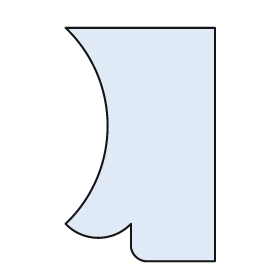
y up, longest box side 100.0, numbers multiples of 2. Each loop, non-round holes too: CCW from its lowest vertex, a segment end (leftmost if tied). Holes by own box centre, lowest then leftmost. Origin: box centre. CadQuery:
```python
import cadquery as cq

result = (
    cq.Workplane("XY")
    .moveTo(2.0, -50.0)
    .lineTo(32.0, -50.0)
    .lineTo(32.0, 50.0)
    .lineTo(-32.0, 50.0)
    .threePointArc((-14.0, 8.0), (-32.0, -34.0))
    .threePointArc((-18.0, -40.0), (-4.0, -34.0))
    .lineTo(-4.0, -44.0)
    .threePointArc((-2.0, -48.0), (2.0, -50.0))
    .close()
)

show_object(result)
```